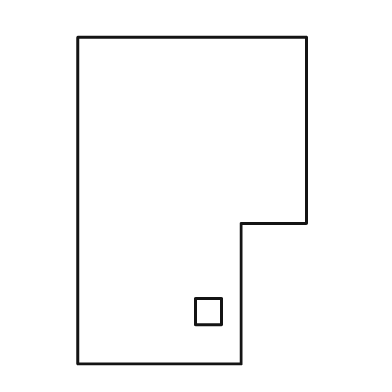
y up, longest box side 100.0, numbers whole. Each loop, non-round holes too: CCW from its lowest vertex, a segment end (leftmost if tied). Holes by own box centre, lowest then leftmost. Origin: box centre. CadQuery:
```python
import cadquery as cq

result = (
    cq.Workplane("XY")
    .moveTo(-35.0, -50.0)
    .lineTo(15.0, -50.0)
    .lineTo(15.0, -7.0)
    .lineTo(35.0, -7.0)
    .lineTo(35.0, 50.0)
    .lineTo(-35.0, 50.0)
    .close()
    .moveTo(1.0, -38.0)
    .lineTo(9.0, -38.0)
    .lineTo(9.0, -30.0)
    .lineTo(1.0, -30.0)
    .close()
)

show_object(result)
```